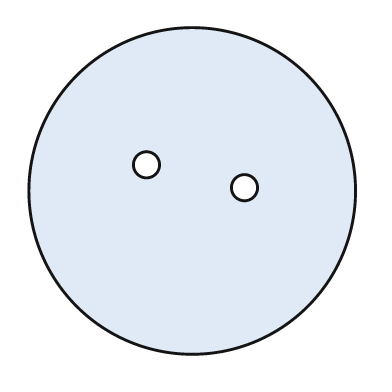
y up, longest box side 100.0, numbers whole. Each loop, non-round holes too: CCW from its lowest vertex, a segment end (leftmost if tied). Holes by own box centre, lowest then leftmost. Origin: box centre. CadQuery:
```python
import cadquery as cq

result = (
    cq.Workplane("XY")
    .moveTo(0.0, 0.0)
    .circle(50.0)
    .moveTo(16.0, 1.0)
    .circle(4.0)
    .moveTo(-14.0, 8.0)
    .circle(4.0)
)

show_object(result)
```